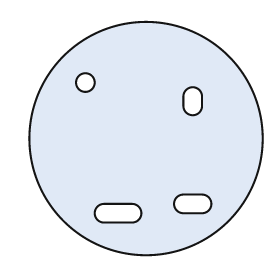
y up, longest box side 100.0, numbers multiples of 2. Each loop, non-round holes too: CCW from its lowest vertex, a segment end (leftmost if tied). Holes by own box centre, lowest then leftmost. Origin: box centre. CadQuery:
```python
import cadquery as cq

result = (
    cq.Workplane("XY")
    .moveTo(0.0, 0.0)
    .circle(50.0)
    .moveTo(-18.0, -36.0)
    .lineTo(-6.0, -36.0)
    .threePointArc((-2.0, -32.0), (-6.0, -28.0))
    .lineTo(-18.0, -28.0)
    .threePointArc((-22.0, -32.0), (-18.0, -36.0))
    .close()
    .moveTo(16.0, -32.0)
    .lineTo(24.0, -32.0)
    .threePointArc((28.0, -28.0), (24.0, -24.0))
    .lineTo(16.0, -24.0)
    .threePointArc((12.0, -28.0), (16.0, -32.0))
    .close()
    .moveTo(16.0, 14.0)
    .threePointArc((20.0, 10.0), (24.0, 14.0))
    .lineTo(24.0, 18.0)
    .threePointArc((20.0, 22.0), (16.0, 18.0))
    .close()
    .moveTo(-26.0, 24.0)
    .circle(4.0)
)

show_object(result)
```